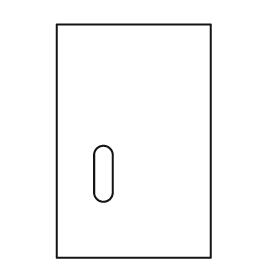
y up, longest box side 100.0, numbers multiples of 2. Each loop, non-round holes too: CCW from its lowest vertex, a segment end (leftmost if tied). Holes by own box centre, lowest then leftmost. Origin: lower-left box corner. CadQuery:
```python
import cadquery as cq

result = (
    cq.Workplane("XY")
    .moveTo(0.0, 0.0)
    .lineTo(66.0, 0.0)
    .lineTo(66.0, 100.0)
    .lineTo(0.0, 100.0)
    .close()
    .moveTo(16.0, 28.0)
    .threePointArc((20.0, 24.0), (24.0, 28.0))
    .lineTo(24.0, 44.0)
    .threePointArc((20.0, 48.0), (16.0, 44.0))
    .close()
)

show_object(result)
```